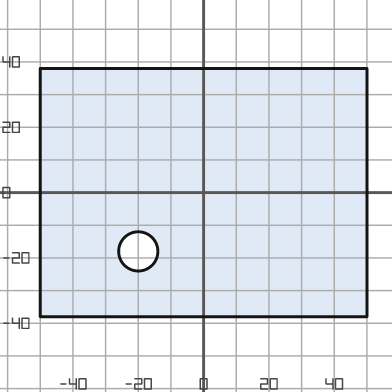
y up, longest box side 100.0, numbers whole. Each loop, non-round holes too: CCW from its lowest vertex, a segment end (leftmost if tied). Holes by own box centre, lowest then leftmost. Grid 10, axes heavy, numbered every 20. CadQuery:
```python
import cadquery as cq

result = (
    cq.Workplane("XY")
    .moveTo(-50.0, -38.0)
    .lineTo(50.0, -38.0)
    .lineTo(50.0, 38.0)
    .lineTo(-50.0, 38.0)
    .close()
    .moveTo(-20.0, -18.0)
    .circle(6.0)
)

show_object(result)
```